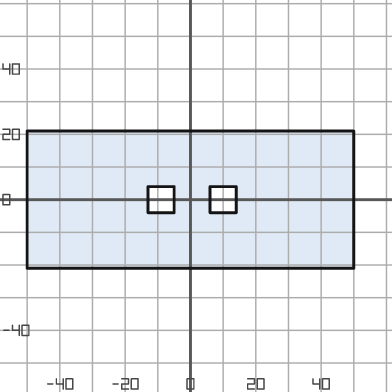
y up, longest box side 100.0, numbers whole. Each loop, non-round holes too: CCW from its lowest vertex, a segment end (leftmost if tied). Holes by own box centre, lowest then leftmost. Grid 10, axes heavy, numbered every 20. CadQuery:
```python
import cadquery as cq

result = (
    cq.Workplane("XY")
    .moveTo(-50.0, -21.0)
    .lineTo(50.0, -21.0)
    .lineTo(50.0, 21.0)
    .lineTo(-50.0, 21.0)
    .close()
    .moveTo(-13.0, -4.0)
    .lineTo(-5.0, -4.0)
    .lineTo(-5.0, 4.0)
    .lineTo(-13.0, 4.0)
    .close()
    .moveTo(6.0, -4.0)
    .lineTo(14.0, -4.0)
    .lineTo(14.0, 4.0)
    .lineTo(6.0, 4.0)
    .close()
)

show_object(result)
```